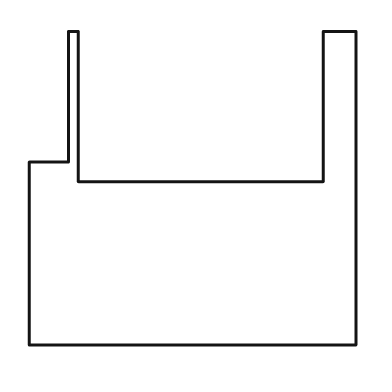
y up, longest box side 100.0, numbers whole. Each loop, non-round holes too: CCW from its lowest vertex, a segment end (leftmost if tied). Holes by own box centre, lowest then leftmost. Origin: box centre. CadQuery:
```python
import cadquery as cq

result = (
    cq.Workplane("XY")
    .moveTo(-50.0, -48.0)
    .lineTo(50.0, -48.0)
    .lineTo(50.0, 48.0)
    .lineTo(40.0, 48.0)
    .lineTo(40.0, 2.0)
    .lineTo(-35.0, 2.0)
    .lineTo(-35.0, 48.0)
    .lineTo(-38.0, 48.0)
    .lineTo(-38.0, 8.0)
    .lineTo(-50.0, 8.0)
    .close()
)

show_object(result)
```